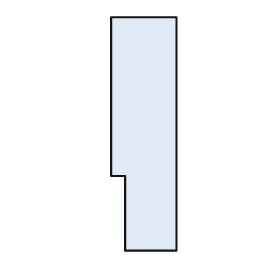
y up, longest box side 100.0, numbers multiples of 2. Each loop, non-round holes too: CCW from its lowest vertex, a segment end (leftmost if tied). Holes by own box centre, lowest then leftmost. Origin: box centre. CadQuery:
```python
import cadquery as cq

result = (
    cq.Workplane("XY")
    .moveTo(-8.0, -50.0)
    .lineTo(14.0, -50.0)
    .lineTo(14.0, 50.0)
    .lineTo(-14.0, 50.0)
    .lineTo(-14.0, -18.0)
    .lineTo(-8.0, -18.0)
    .close()
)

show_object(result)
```